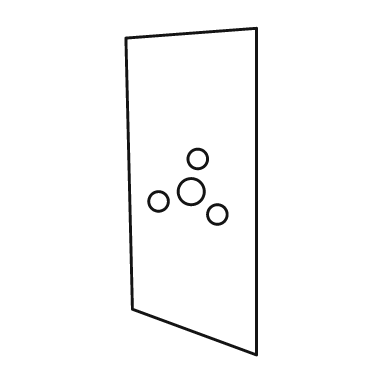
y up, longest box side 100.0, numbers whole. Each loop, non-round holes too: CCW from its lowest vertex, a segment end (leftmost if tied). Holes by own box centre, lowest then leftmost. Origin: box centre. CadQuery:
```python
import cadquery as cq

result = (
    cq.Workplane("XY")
    .moveTo(20.0, -50.0)
    .lineTo(20.0, 50.0)
    .lineTo(-20.0, 47.0)
    .lineTo(-18.0, -36.0)
    .close()
    .moveTo(8.0, -7.0)
    .circle(3.0)
    .moveTo(-10.0, -3.0)
    .circle(3.0)
    .moveTo(0.0, 0.0)
    .circle(4.0)
    .moveTo(2.0, 10.0)
    .circle(3.0)
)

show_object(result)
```